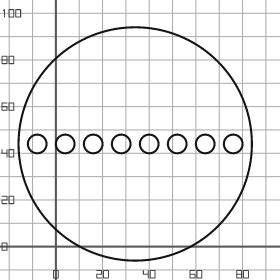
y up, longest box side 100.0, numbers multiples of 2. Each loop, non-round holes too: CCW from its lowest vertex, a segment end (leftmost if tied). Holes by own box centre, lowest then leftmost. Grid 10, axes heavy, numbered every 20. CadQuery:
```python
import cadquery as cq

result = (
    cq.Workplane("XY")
    .moveTo(34.0, 44.0)
    .circle(50.0)
    .moveTo(-8.0, 44.0)
    .circle(4.0)
    .moveTo(4.0, 44.0)
    .circle(4.0)
    .moveTo(16.0, 44.0)
    .circle(4.0)
    .moveTo(28.0, 44.0)
    .circle(4.0)
    .moveTo(40.0, 44.0)
    .circle(4.0)
    .moveTo(52.0, 44.0)
    .circle(4.0)
    .moveTo(64.0, 44.0)
    .circle(4.0)
    .moveTo(76.0, 44.0)
    .circle(4.0)
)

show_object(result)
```